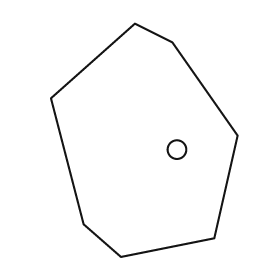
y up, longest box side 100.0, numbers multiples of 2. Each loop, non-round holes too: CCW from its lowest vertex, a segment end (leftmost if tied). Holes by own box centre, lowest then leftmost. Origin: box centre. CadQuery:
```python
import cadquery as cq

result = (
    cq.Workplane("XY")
    .moveTo(-10.0, -50.0)
    .lineTo(30.0, -42.0)
    .lineTo(40.0, 2.0)
    .lineTo(12.0, 42.0)
    .lineTo(-4.0, 50.0)
    .lineTo(-40.0, 18.0)
    .lineTo(-26.0, -36.0)
    .close()
    .moveTo(14.0, -4.0)
    .circle(4.0)
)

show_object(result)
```